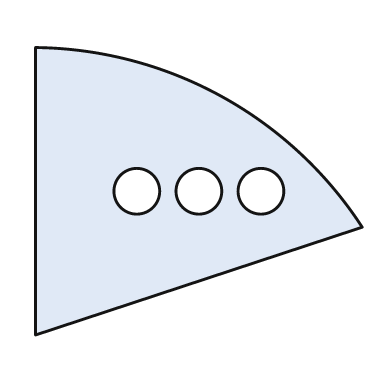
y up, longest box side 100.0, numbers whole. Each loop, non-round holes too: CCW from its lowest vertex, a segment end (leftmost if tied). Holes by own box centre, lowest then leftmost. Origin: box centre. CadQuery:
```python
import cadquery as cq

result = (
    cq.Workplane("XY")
    .moveTo(-50.0, -44.0)
    .lineTo(50.0, -11.0)
    .threePointArc((7.0, 29.0), (-50.0, 44.0))
    .close()
    .moveTo(-19.0, 0.0)
    .circle(7.0)
    .moveTo(0.0, 0.0)
    .circle(7.0)
    .moveTo(19.0, 0.0)
    .circle(7.0)
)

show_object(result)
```